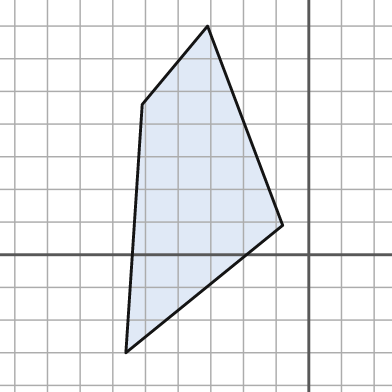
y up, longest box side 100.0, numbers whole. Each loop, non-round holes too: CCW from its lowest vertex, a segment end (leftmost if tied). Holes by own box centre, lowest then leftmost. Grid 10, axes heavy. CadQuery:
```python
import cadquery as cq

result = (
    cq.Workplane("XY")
    .moveTo(-56.0, -30.0)
    .lineTo(-8.0, 9.0)
    .lineTo(-31.0, 70.0)
    .lineTo(-51.0, 46.0)
    .close()
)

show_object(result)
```